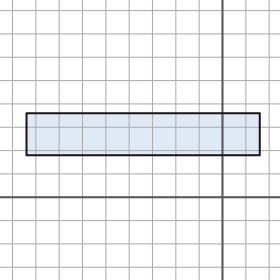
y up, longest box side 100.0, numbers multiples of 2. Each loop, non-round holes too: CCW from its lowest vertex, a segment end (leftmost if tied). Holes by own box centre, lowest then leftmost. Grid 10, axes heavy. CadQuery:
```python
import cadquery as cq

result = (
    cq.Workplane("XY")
    .moveTo(-84.0, 18.0)
    .lineTo(16.0, 18.0)
    .lineTo(16.0, 36.0)
    .lineTo(-84.0, 36.0)
    .close()
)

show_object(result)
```